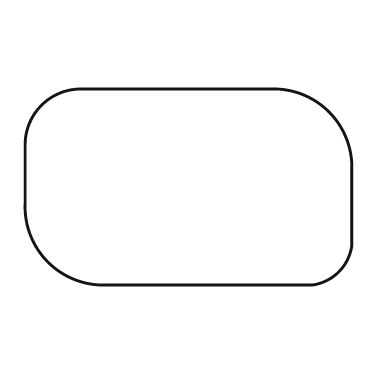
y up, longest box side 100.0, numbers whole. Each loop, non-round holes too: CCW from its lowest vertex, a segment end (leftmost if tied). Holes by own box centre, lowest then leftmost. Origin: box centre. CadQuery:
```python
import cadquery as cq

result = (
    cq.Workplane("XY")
    .moveTo(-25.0, -30.0)
    .lineTo(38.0, -30.0)
    .threePointArc((46.0, -26.0), (50.0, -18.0))
    .lineTo(50.0, 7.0)
    .threePointArc((43.0, 23.0), (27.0, 30.0))
    .lineTo(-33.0, 30.0)
    .threePointArc((-45.0, 25.0), (-50.0, 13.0))
    .lineTo(-50.0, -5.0)
    .threePointArc((-43.0, -23.0), (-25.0, -30.0))
    .close()
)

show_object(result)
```